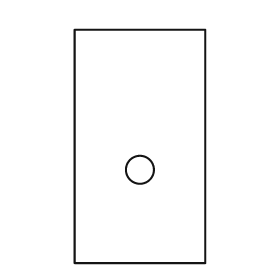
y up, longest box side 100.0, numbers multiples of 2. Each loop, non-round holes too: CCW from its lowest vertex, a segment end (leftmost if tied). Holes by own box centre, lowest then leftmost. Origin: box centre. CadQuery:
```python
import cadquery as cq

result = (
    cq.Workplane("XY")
    .moveTo(-28.0, -50.0)
    .lineTo(28.0, -50.0)
    .lineTo(28.0, 50.0)
    .lineTo(-28.0, 50.0)
    .close()
    .moveTo(0.0, -10.0)
    .circle(6.0)
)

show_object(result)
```